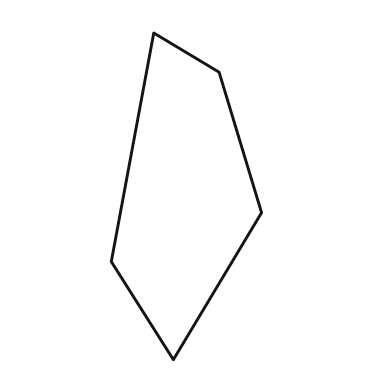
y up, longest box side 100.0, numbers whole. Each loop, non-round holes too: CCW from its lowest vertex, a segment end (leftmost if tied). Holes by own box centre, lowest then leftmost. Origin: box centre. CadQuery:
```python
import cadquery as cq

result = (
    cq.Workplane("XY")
    .moveTo(-4.0, -50.0)
    .lineTo(23.0, -5.0)
    .lineTo(10.0, 38.0)
    .lineTo(-10.0, 50.0)
    .lineTo(-23.0, -20.0)
    .close()
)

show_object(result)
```